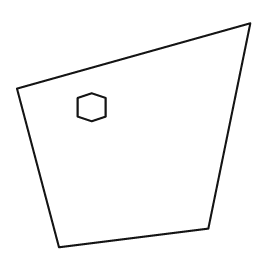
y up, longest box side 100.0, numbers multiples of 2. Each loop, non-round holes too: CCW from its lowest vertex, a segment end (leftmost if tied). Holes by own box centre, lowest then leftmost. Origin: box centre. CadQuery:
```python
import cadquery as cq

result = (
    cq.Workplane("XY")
    .moveTo(-32.0, -48.0)
    .lineTo(32.0, -40.0)
    .lineTo(50.0, 48.0)
    .lineTo(-50.0, 20.0)
    .close()
    .moveTo(-18.0, 6.0)
    .lineTo(-12.0, 8.0)
    .lineTo(-12.0, 16.0)
    .lineTo(-18.0, 18.0)
    .lineTo(-24.0, 16.0)
    .lineTo(-24.0, 8.0)
    .close()
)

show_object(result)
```